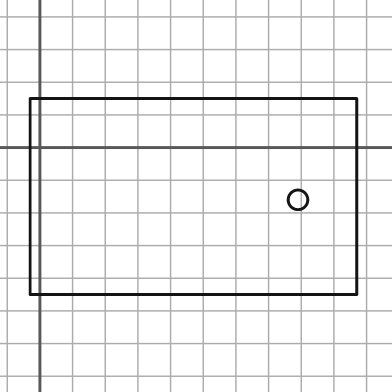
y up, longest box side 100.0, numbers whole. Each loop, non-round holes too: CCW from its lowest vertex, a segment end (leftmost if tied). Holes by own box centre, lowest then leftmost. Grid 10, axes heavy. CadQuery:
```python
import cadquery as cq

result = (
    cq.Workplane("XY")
    .moveTo(-3.0, -45.0)
    .lineTo(97.0, -45.0)
    .lineTo(97.0, 15.0)
    .lineTo(-3.0, 15.0)
    .close()
    .moveTo(79.0, -16.0)
    .circle(3.0)
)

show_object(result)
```